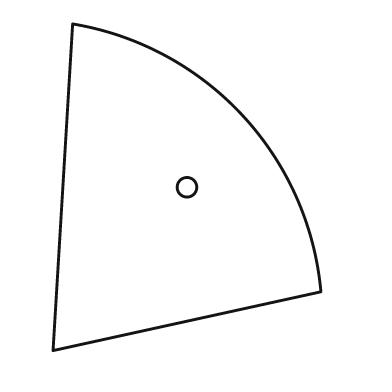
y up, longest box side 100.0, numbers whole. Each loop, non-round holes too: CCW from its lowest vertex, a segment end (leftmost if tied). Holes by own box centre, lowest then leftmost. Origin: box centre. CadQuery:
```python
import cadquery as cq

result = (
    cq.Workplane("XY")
    .moveTo(-41.0, -50.0)
    .lineTo(41.0, -32.0)
    .threePointArc((17.0, 22.0), (-35.0, 50.0))
    .close()
    .moveTo(0.0, 0.0)
    .circle(3.0)
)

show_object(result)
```